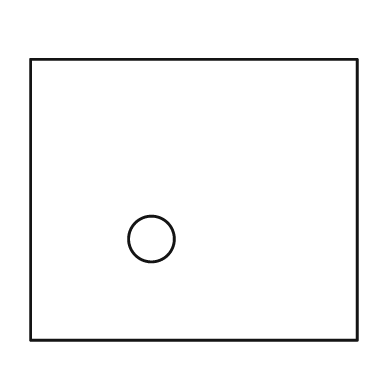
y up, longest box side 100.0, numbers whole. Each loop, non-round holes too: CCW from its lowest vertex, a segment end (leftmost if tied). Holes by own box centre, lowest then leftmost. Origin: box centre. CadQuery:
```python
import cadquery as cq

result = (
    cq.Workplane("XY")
    .moveTo(-50.0, -43.0)
    .lineTo(50.0, -43.0)
    .lineTo(50.0, 43.0)
    .lineTo(-50.0, 43.0)
    .close()
    .moveTo(-13.0, -12.0)
    .circle(7.0)
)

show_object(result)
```